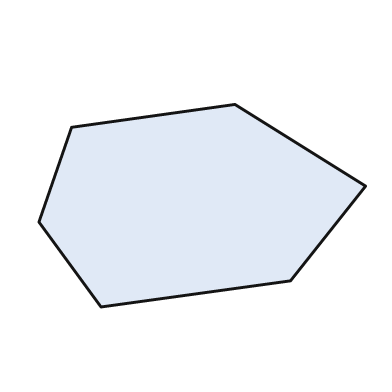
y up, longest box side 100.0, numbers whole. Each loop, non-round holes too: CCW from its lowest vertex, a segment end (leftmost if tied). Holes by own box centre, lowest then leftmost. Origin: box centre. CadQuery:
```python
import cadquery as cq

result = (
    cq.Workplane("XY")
    .moveTo(-31.0, -31.0)
    .lineTo(27.0, -23.0)
    .lineTo(50.0, 6.0)
    .lineTo(10.0, 31.0)
    .lineTo(-40.0, 24.0)
    .lineTo(-50.0, -5.0)
    .close()
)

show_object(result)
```